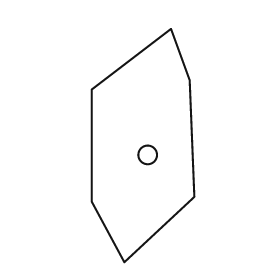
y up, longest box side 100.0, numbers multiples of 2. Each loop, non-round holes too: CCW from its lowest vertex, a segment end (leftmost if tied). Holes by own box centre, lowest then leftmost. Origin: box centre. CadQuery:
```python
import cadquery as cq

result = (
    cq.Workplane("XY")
    .moveTo(-8.0, -50.0)
    .lineTo(22.0, -22.0)
    .lineTo(20.0, 28.0)
    .lineTo(12.0, 50.0)
    .lineTo(-22.0, 24.0)
    .lineTo(-22.0, -24.0)
    .close()
    .moveTo(2.0, -4.0)
    .circle(4.0)
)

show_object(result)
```